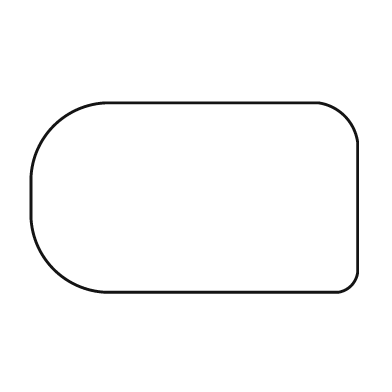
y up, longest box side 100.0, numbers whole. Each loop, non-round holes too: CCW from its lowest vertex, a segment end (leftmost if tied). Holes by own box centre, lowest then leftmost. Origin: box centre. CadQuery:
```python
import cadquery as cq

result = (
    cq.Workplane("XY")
    .moveTo(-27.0, -29.0)
    .lineTo(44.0, -29.0)
    .threePointArc((48.0, -27.0), (50.0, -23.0))
    .lineTo(50.0, 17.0)
    .threePointArc((46.0, 25.0), (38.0, 29.0))
    .lineTo(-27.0, 29.0)
    .threePointArc((-43.0, 22.0), (-50.0, 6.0))
    .lineTo(-50.0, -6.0)
    .threePointArc((-43.0, -22.0), (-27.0, -29.0))
    .close()
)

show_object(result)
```